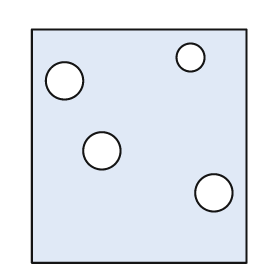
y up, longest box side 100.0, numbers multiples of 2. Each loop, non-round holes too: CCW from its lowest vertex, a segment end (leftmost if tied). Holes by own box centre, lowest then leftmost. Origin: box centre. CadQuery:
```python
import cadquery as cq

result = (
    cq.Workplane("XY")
    .moveTo(-46.0, -50.0)
    .lineTo(46.0, -50.0)
    .lineTo(46.0, 50.0)
    .lineTo(-46.0, 50.0)
    .close()
    .moveTo(32.0, -20.0)
    .circle(8.0)
    .moveTo(-16.0, -2.0)
    .circle(8.0)
    .moveTo(-32.0, 28.0)
    .circle(8.0)
    .moveTo(22.0, 38.0)
    .circle(6.0)
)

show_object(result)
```